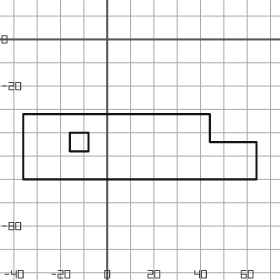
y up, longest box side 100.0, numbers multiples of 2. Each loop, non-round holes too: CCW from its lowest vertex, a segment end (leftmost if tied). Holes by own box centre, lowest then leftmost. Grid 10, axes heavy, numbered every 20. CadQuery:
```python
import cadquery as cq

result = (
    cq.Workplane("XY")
    .moveTo(-36.0, -60.0)
    .lineTo(64.0, -60.0)
    .lineTo(64.0, -44.0)
    .lineTo(44.0, -44.0)
    .lineTo(44.0, -32.0)
    .lineTo(-36.0, -32.0)
    .close()
    .moveTo(-16.0, -48.0)
    .lineTo(-8.0, -48.0)
    .lineTo(-8.0, -40.0)
    .lineTo(-16.0, -40.0)
    .close()
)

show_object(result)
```